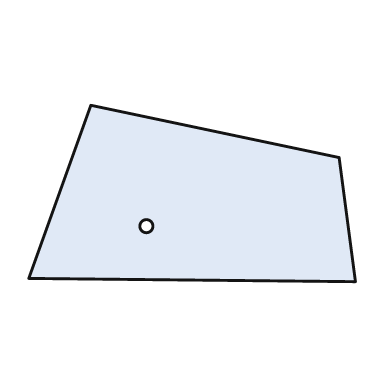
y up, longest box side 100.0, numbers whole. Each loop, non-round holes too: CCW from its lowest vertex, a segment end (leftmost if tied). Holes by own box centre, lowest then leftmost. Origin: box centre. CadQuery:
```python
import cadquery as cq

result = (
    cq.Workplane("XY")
    .moveTo(50.0, -27.0)
    .lineTo(45.0, 11.0)
    .lineTo(-31.0, 27.0)
    .lineTo(-50.0, -26.0)
    .close()
    .moveTo(-14.0, -10.0)
    .circle(2.0)
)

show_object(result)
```